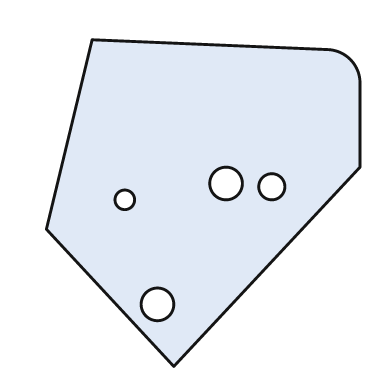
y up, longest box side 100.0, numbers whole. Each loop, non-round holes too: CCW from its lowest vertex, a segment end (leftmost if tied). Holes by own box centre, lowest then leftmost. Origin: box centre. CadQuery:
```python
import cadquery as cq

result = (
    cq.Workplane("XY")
    .moveTo(-9.0, -50.0)
    .lineTo(48.0, 11.0)
    .lineTo(48.0, 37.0)
    .threePointArc((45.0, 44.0), (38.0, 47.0))
    .lineTo(-34.0, 50.0)
    .lineTo(-48.0, -8.0)
    .close()
    .moveTo(-14.0, -31.0)
    .circle(5.0)
    .moveTo(-24.0, 1.0)
    .circle(3.0)
    .moveTo(21.0, 5.0)
    .circle(4.0)
    .moveTo(7.0, 6.0)
    .circle(5.0)
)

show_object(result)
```